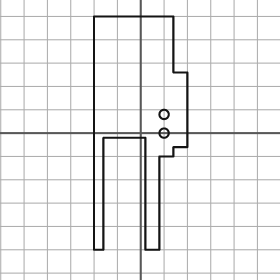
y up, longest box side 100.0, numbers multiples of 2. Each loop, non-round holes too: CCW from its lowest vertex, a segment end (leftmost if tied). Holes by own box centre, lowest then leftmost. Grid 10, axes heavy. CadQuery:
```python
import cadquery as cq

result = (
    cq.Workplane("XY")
    .moveTo(-20.0, -50.0)
    .lineTo(-16.0, -50.0)
    .lineTo(-16.0, -2.0)
    .lineTo(2.0, -2.0)
    .lineTo(2.0, -50.0)
    .lineTo(8.0, -50.0)
    .lineTo(8.0, -10.0)
    .lineTo(14.0, -10.0)
    .lineTo(14.0, -6.0)
    .lineTo(20.0, -6.0)
    .lineTo(20.0, 26.0)
    .lineTo(14.0, 26.0)
    .lineTo(14.0, 50.0)
    .lineTo(-20.0, 50.0)
    .close()
    .moveTo(10.0, 0.0)
    .circle(2.0)
    .moveTo(10.0, 8.0)
    .circle(2.0)
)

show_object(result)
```